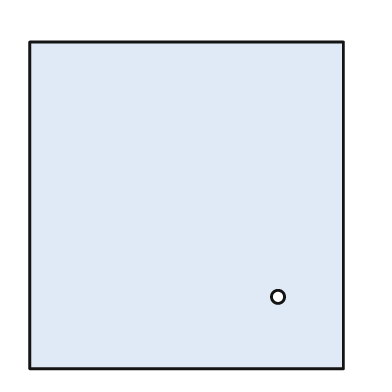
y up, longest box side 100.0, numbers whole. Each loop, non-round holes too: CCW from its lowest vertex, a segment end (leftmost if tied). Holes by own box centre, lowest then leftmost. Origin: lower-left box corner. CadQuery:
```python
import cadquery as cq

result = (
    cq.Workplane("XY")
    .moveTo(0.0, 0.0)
    .lineTo(96.0, 0.0)
    .lineTo(96.0, 100.0)
    .lineTo(0.0, 100.0)
    .close()
    .moveTo(76.0, 22.0)
    .circle(2.0)
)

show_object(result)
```